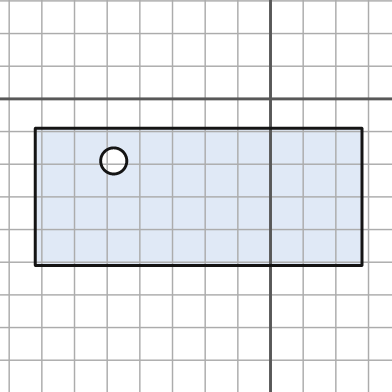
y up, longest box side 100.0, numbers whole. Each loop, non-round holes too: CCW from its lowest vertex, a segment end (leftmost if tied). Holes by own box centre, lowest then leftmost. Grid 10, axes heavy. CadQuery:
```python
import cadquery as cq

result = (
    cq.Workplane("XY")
    .moveTo(-72.0, -51.0)
    .lineTo(28.0, -51.0)
    .lineTo(28.0, -9.0)
    .lineTo(-72.0, -9.0)
    .close()
    .moveTo(-48.0, -19.0)
    .circle(4.0)
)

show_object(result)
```